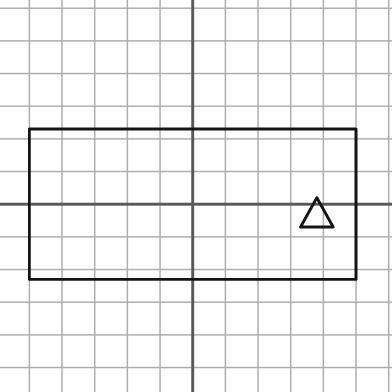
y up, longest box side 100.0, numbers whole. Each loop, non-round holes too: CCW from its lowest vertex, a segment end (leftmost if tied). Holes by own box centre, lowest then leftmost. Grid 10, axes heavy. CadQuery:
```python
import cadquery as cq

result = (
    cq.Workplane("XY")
    .moveTo(-50.0, -23.0)
    .lineTo(50.0, -23.0)
    .lineTo(50.0, 23.0)
    .lineTo(-50.0, 23.0)
    .close()
    .moveTo(33.0, -7.0)
    .lineTo(43.0, -7.0)
    .lineTo(38.0, 2.0)
    .close()
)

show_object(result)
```